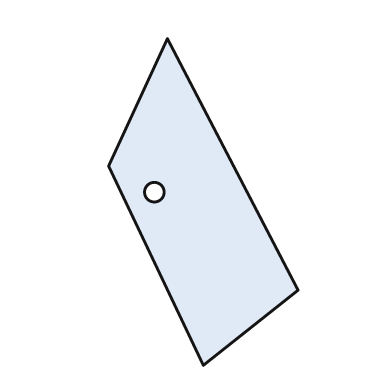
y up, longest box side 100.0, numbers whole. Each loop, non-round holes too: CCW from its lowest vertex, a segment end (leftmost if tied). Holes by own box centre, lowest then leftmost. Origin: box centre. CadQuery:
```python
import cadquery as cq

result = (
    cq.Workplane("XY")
    .moveTo(0.0, -50.0)
    .lineTo(29.0, -27.0)
    .lineTo(-11.0, 50.0)
    .lineTo(-29.0, 11.0)
    .close()
    .moveTo(-15.0, 3.0)
    .circle(3.0)
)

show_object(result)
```